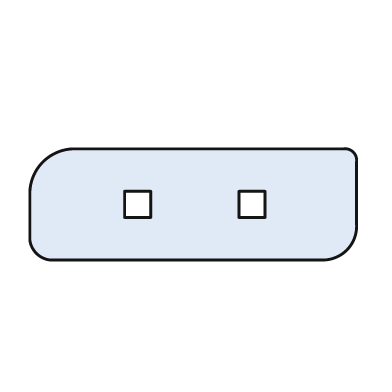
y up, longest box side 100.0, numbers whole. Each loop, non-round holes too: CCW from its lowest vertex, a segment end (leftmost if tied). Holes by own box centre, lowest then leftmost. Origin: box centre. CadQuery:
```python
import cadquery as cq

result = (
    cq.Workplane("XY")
    .moveTo(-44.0, -17.0)
    .lineTo(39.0, -17.0)
    .threePointArc((47.0, -14.0), (50.0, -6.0))
    .lineTo(50.0, 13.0)
    .threePointArc((49.0, 16.0), (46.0, 17.0))
    .lineTo(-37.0, 17.0)
    .threePointArc((-46.0, 13.0), (-50.0, 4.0))
    .lineTo(-50.0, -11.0)
    .threePointArc((-48.0, -15.0), (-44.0, -17.0))
    .close()
    .moveTo(-21.0, -4.0)
    .lineTo(-13.0, -4.0)
    .lineTo(-13.0, 4.0)
    .lineTo(-21.0, 4.0)
    .close()
    .moveTo(14.0, -4.0)
    .lineTo(22.0, -4.0)
    .lineTo(22.0, 4.0)
    .lineTo(14.0, 4.0)
    .close()
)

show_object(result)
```